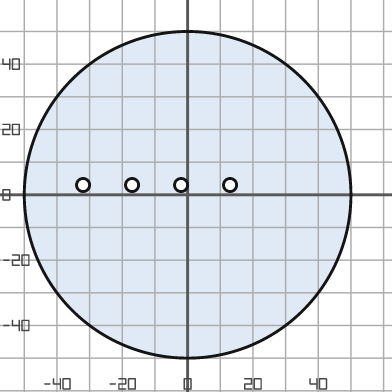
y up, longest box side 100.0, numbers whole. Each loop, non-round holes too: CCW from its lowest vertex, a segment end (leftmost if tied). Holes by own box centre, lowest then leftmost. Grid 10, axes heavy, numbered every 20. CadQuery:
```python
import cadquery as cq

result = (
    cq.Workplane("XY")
    .moveTo(0.0, 0.0)
    .circle(50.0)
    .moveTo(-32.0, 3.0)
    .circle(2.0)
    .moveTo(-17.0, 3.0)
    .circle(2.0)
    .moveTo(-2.0, 3.0)
    .circle(2.0)
    .moveTo(13.0, 3.0)
    .circle(2.0)
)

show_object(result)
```